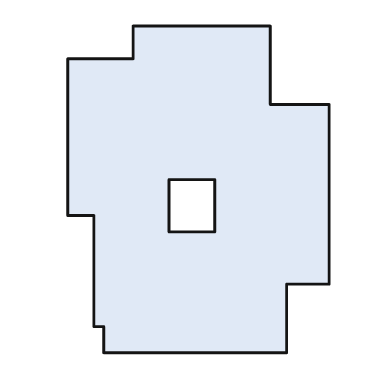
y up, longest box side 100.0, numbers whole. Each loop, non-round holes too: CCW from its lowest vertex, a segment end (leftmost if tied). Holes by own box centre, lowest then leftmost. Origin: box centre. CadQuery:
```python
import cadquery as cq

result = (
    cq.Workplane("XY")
    .moveTo(-29.0, -50.0)
    .lineTo(27.0, -50.0)
    .lineTo(27.0, -29.0)
    .lineTo(40.0, -29.0)
    .lineTo(40.0, 26.0)
    .lineTo(22.0, 26.0)
    .lineTo(22.0, 50.0)
    .lineTo(-20.0, 50.0)
    .lineTo(-20.0, 40.0)
    .lineTo(-40.0, 40.0)
    .lineTo(-40.0, -8.0)
    .lineTo(-32.0, -8.0)
    .lineTo(-32.0, -42.0)
    .lineTo(-29.0, -42.0)
    .close()
    .moveTo(-9.0, -13.0)
    .lineTo(5.0, -13.0)
    .lineTo(5.0, 3.0)
    .lineTo(-9.0, 3.0)
    .close()
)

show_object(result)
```